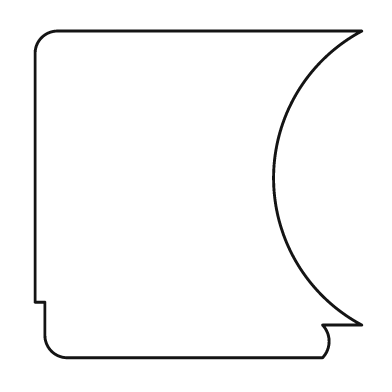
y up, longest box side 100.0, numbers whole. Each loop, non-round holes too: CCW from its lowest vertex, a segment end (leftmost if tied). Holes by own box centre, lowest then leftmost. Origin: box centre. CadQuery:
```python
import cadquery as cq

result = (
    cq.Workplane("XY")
    .moveTo(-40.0, -50.0)
    .lineTo(38.0, -50.0)
    .threePointArc((40.0, -45.0), (38.0, -40.0))
    .lineTo(50.0, -40.0)
    .threePointArc((23.0, 5.0), (50.0, 50.0))
    .lineTo(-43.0, 50.0)
    .threePointArc((-48.0, 48.0), (-50.0, 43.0))
    .lineTo(-50.0, -33.0)
    .lineTo(-47.0, -33.0)
    .lineTo(-47.0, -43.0)
    .threePointArc((-45.0, -48.0), (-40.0, -50.0))
    .close()
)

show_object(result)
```